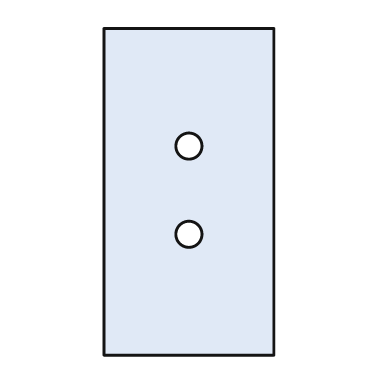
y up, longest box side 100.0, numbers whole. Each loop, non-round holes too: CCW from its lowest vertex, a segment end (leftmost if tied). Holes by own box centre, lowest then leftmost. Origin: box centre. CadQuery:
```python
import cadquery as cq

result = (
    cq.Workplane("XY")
    .moveTo(-26.0, -50.0)
    .lineTo(26.0, -50.0)
    .lineTo(26.0, 50.0)
    .lineTo(-26.0, 50.0)
    .close()
    .moveTo(0.0, -13.0)
    .circle(4.0)
    .moveTo(0.0, 14.0)
    .circle(4.0)
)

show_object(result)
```